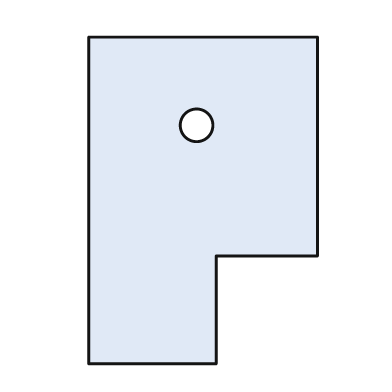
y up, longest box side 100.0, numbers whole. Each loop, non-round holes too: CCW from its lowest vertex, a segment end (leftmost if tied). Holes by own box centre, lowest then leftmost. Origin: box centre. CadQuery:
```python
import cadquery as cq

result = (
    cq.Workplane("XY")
    .moveTo(-35.0, -50.0)
    .lineTo(4.0, -50.0)
    .lineTo(4.0, -17.0)
    .lineTo(35.0, -17.0)
    .lineTo(35.0, 50.0)
    .lineTo(-35.0, 50.0)
    .close()
    .moveTo(-2.0, 23.0)
    .circle(5.0)
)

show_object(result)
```